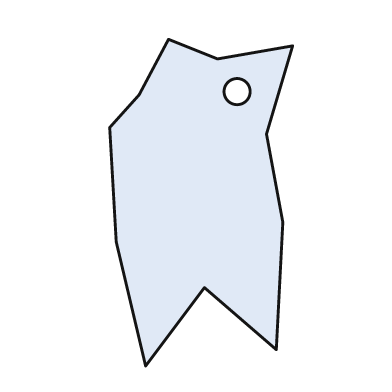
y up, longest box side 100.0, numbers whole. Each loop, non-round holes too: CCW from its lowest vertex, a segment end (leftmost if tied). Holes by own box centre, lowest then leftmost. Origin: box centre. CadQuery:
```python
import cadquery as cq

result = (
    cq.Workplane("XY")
    .moveTo(-17.0, -50.0)
    .lineTo(1.0, -26.0)
    .lineTo(23.0, -45.0)
    .lineTo(25.0, -6.0)
    .lineTo(20.0, 21.0)
    .lineTo(28.0, 48.0)
    .lineTo(5.0, 44.0)
    .lineTo(-10.0, 50.0)
    .lineTo(-19.0, 33.0)
    .lineTo(-28.0, 23.0)
    .lineTo(-26.0, -12.0)
    .close()
    .moveTo(11.0, 34.0)
    .circle(4.0)
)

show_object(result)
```